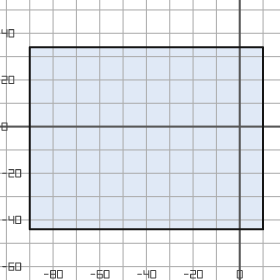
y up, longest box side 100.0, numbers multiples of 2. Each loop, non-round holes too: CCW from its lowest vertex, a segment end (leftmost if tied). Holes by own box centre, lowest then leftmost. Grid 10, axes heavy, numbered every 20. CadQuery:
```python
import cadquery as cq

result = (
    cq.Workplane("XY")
    .moveTo(-90.0, -44.0)
    .lineTo(10.0, -44.0)
    .lineTo(10.0, 34.0)
    .lineTo(-90.0, 34.0)
    .close()
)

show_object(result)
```